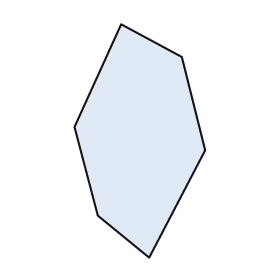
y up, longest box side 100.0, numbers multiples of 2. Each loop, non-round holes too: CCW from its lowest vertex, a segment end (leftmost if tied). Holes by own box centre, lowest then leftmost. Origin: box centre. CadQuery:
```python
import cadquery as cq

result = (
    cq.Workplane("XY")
    .moveTo(4.0, -50.0)
    .lineTo(28.0, -4.0)
    .lineTo(18.0, 36.0)
    .lineTo(-8.0, 50.0)
    .lineTo(-28.0, 6.0)
    .lineTo(-18.0, -32.0)
    .close()
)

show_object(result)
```